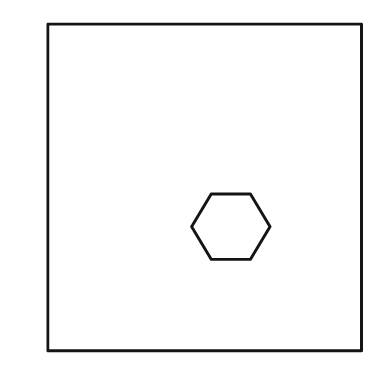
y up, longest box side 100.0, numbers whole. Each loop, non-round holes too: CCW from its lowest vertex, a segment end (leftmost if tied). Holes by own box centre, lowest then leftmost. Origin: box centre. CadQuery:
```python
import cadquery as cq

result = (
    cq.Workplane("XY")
    .moveTo(-48.0, -50.0)
    .lineTo(48.0, -50.0)
    .lineTo(48.0, 50.0)
    .lineTo(-48.0, 50.0)
    .close()
    .moveTo(2.0, -22.0)
    .lineTo(14.0, -22.0)
    .lineTo(20.0, -12.0)
    .lineTo(14.0, -2.0)
    .lineTo(2.0, -2.0)
    .lineTo(-4.0, -12.0)
    .close()
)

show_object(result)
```